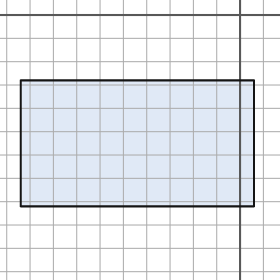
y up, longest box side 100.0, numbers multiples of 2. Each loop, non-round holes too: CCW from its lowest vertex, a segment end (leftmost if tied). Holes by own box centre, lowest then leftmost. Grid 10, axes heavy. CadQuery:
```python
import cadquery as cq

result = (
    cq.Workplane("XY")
    .moveTo(-94.0, -82.0)
    .lineTo(6.0, -82.0)
    .lineTo(6.0, -28.0)
    .lineTo(-94.0, -28.0)
    .close()
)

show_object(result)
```